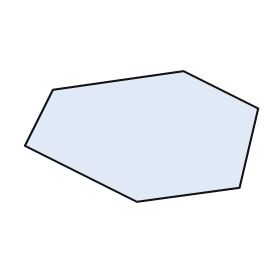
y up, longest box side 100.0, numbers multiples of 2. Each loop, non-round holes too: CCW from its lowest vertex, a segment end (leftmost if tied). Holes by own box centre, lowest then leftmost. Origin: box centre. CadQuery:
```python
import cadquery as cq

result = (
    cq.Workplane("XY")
    .moveTo(-2.0, -28.0)
    .lineTo(42.0, -22.0)
    .lineTo(50.0, 12.0)
    .lineTo(18.0, 28.0)
    .lineTo(-38.0, 20.0)
    .lineTo(-50.0, -4.0)
    .close()
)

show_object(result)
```